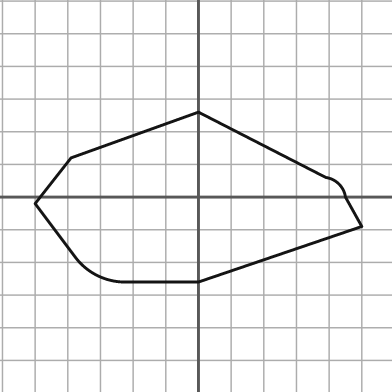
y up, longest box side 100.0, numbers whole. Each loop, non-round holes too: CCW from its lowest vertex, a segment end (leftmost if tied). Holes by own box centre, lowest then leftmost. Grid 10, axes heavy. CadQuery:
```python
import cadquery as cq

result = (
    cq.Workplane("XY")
    .moveTo(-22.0, -26.0)
    .lineTo(0.0, -26.0)
    .lineTo(50.0, -9.0)
    .lineTo(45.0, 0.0)
    .threePointArc((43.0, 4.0), (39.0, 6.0))
    .lineTo(0.0, 26.0)
    .lineTo(-39.0, 12.0)
    .lineTo(-50.0, -2.0)
    .lineTo(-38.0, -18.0)
    .threePointArc((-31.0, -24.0), (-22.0, -26.0))
    .close()
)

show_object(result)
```